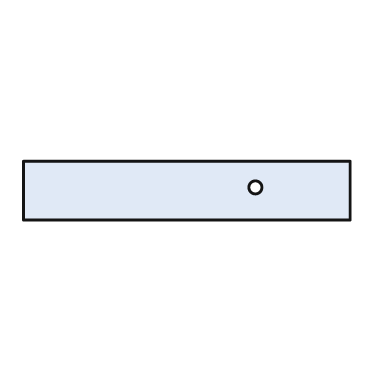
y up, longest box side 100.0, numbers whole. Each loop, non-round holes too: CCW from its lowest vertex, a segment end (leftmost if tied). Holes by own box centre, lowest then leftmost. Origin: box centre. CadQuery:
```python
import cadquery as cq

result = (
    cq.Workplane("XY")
    .moveTo(-50.0, -9.0)
    .lineTo(50.0, -9.0)
    .lineTo(50.0, 9.0)
    .lineTo(-50.0, 9.0)
    .close()
    .moveTo(21.0, 1.0)
    .circle(2.0)
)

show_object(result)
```